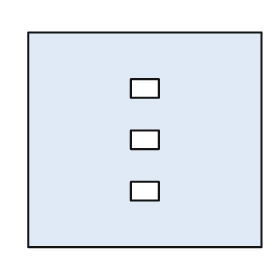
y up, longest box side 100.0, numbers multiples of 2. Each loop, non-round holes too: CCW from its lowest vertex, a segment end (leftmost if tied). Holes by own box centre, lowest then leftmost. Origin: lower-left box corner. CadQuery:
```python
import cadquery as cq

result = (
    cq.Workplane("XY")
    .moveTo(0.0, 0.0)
    .lineTo(100.0, 0.0)
    .lineTo(100.0, 92.0)
    .lineTo(0.0, 92.0)
    .close()
    .moveTo(44.0, 20.0)
    .lineTo(56.0, 20.0)
    .lineTo(56.0, 28.0)
    .lineTo(44.0, 28.0)
    .close()
    .moveTo(44.0, 42.0)
    .lineTo(56.0, 42.0)
    .lineTo(56.0, 50.0)
    .lineTo(44.0, 50.0)
    .close()
    .moveTo(44.0, 64.0)
    .lineTo(56.0, 64.0)
    .lineTo(56.0, 72.0)
    .lineTo(44.0, 72.0)
    .close()
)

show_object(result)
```